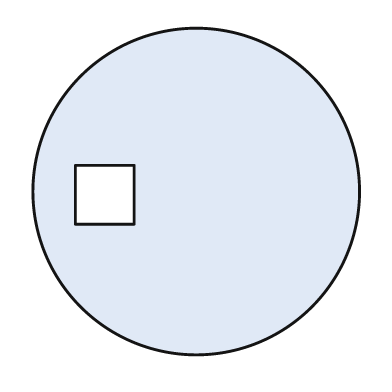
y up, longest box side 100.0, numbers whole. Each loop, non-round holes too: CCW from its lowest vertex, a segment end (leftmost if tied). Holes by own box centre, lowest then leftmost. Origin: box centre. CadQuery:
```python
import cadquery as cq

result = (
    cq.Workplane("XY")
    .moveTo(0.0, 0.0)
    .circle(50.0)
    .moveTo(-37.0, -10.0)
    .lineTo(-19.0, -10.0)
    .lineTo(-19.0, 8.0)
    .lineTo(-37.0, 8.0)
    .close()
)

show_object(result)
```